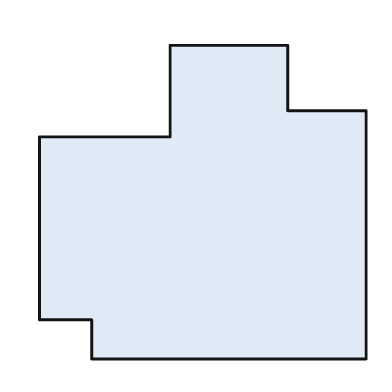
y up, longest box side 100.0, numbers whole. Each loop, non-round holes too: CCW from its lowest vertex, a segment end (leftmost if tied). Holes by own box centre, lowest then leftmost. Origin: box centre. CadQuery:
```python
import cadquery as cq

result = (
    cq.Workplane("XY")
    .moveTo(-34.0, -48.0)
    .lineTo(50.0, -48.0)
    .lineTo(50.0, 28.0)
    .lineTo(26.0, 28.0)
    .lineTo(26.0, 48.0)
    .lineTo(-10.0, 48.0)
    .lineTo(-10.0, 20.0)
    .lineTo(-50.0, 20.0)
    .lineTo(-50.0, -36.0)
    .lineTo(-34.0, -36.0)
    .close()
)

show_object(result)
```